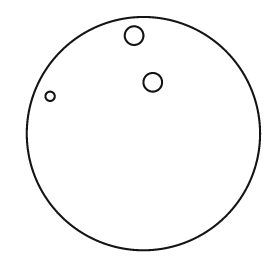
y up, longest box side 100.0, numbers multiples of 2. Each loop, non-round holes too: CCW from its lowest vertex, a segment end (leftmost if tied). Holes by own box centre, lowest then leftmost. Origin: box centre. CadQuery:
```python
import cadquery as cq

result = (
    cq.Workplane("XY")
    .moveTo(0.0, 0.0)
    .circle(50.0)
    .moveTo(-40.0, 16.0)
    .circle(2.0)
    .moveTo(4.0, 22.0)
    .circle(4.0)
    .moveTo(-4.0, 42.0)
    .circle(4.0)
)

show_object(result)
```